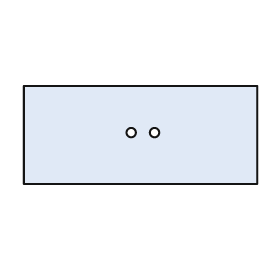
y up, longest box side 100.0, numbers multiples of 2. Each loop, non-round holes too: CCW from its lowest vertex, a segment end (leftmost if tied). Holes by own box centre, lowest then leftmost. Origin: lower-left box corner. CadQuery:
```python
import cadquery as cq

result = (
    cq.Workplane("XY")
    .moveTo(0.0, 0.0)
    .lineTo(100.0, 0.0)
    .lineTo(100.0, 42.0)
    .lineTo(0.0, 42.0)
    .close()
    .moveTo(46.0, 22.0)
    .circle(2.0)
    .moveTo(56.0, 22.0)
    .circle(2.0)
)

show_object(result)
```